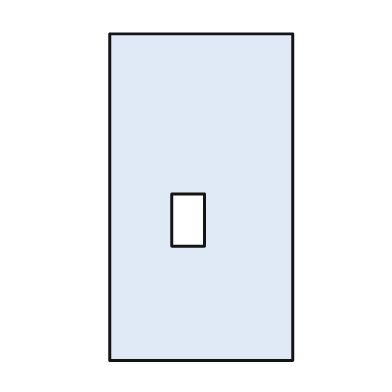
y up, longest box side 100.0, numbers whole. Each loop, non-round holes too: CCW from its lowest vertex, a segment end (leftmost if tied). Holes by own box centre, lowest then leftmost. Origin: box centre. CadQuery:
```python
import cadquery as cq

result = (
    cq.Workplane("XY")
    .moveTo(-28.0, -50.0)
    .lineTo(28.0, -50.0)
    .lineTo(28.0, 50.0)
    .lineTo(-28.0, 50.0)
    .close()
    .moveTo(-9.0, -15.0)
    .lineTo(1.0, -15.0)
    .lineTo(1.0, 1.0)
    .lineTo(-9.0, 1.0)
    .close()
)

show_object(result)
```